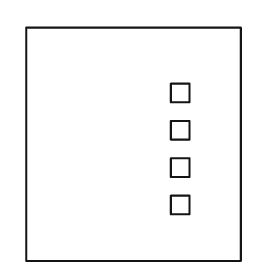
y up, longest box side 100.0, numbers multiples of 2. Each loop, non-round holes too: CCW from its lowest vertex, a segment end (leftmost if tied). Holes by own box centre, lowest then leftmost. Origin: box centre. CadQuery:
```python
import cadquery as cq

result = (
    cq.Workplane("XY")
    .moveTo(-46.0, -50.0)
    .lineTo(46.0, -50.0)
    .lineTo(46.0, 50.0)
    .lineTo(-46.0, 50.0)
    .close()
    .moveTo(16.0, -30.0)
    .lineTo(24.0, -30.0)
    .lineTo(24.0, -22.0)
    .lineTo(16.0, -22.0)
    .close()
    .moveTo(16.0, -14.0)
    .lineTo(24.0, -14.0)
    .lineTo(24.0, -6.0)
    .lineTo(16.0, -6.0)
    .close()
    .moveTo(16.0, 2.0)
    .lineTo(24.0, 2.0)
    .lineTo(24.0, 10.0)
    .lineTo(16.0, 10.0)
    .close()
    .moveTo(16.0, 18.0)
    .lineTo(24.0, 18.0)
    .lineTo(24.0, 26.0)
    .lineTo(16.0, 26.0)
    .close()
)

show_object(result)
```